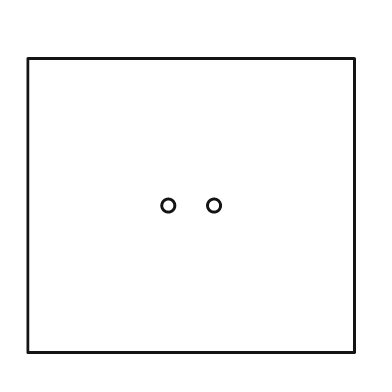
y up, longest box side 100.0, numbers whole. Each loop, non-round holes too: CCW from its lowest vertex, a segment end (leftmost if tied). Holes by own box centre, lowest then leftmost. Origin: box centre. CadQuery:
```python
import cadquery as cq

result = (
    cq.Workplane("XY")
    .moveTo(-50.0, -45.0)
    .lineTo(50.0, -45.0)
    .lineTo(50.0, 45.0)
    .lineTo(-50.0, 45.0)
    .close()
    .moveTo(-7.0, 0.0)
    .circle(2.0)
    .moveTo(7.0, 0.0)
    .circle(2.0)
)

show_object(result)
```